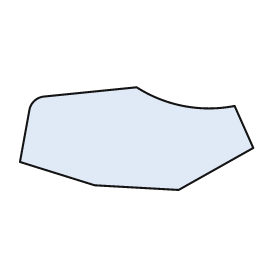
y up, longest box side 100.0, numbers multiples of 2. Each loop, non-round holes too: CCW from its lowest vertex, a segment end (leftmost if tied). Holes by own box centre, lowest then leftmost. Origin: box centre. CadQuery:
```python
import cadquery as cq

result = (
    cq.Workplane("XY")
    .moveTo(18.0, -22.0)
    .lineTo(50.0, -4.0)
    .lineTo(42.0, 14.0)
    .threePointArc((20.0, 14.0), (0.0, 22.0))
    .lineTo(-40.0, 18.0)
    .threePointArc((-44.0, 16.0), (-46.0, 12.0))
    .lineTo(-50.0, -10.0)
    .lineTo(-18.0, -20.0)
    .close()
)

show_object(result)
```